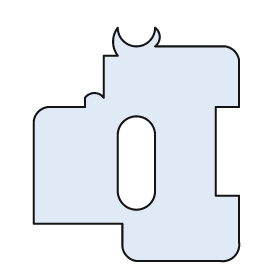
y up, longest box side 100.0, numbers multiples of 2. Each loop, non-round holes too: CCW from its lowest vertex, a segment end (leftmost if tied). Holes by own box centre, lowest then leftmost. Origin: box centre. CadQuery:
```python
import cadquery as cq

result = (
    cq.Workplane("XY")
    .moveTo(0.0, -50.0)
    .lineTo(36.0, -50.0)
    .threePointArc((42.0, -48.0), (44.0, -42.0))
    .lineTo(44.0, -22.0)
    .lineTo(34.0, -22.0)
    .lineTo(34.0, 16.0)
    .lineTo(44.0, 16.0)
    .lineTo(44.0, 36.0)
    .threePointArc((42.0, 40.0), (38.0, 42.0))
    .lineTo(8.0, 42.0)
    .threePointArc((10.0, 46.0), (8.0, 50.0))
    .threePointArc((0.0, 42.0), (-8.0, 50.0))
    .threePointArc((-10.0, 44.0), (-8.0, 38.0))
    .lineTo(-14.0, 38.0)
    .lineTo(-14.0, 20.0)
    .threePointArc((-18.0, 22.0), (-22.0, 20.0))
    .lineTo(-22.0, 16.0)
    .lineTo(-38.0, 16.0)
    .threePointArc((-42.0, 14.0), (-44.0, 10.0))
    .lineTo(-44.0, -34.0)
    .lineTo(-6.0, -34.0)
    .lineTo(-6.0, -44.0)
    .threePointArc((-4.0, -48.0), (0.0, -50.0))
    .close()
    .moveTo(-8.0, -20.0)
    .threePointArc((0.0, -28.0), (8.0, -20.0))
    .lineTo(8.0, 4.0)
    .threePointArc((0.0, 12.0), (-8.0, 4.0))
    .close()
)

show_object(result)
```